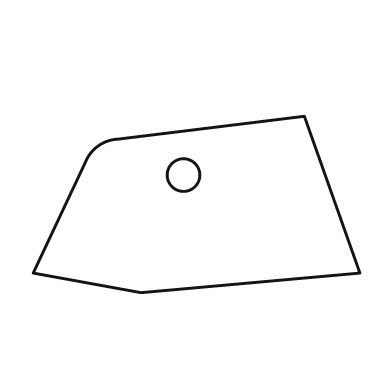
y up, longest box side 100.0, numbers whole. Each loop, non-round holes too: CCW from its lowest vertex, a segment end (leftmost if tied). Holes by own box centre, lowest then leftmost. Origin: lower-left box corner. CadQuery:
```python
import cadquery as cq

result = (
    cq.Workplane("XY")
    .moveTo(33.0, 0.0)
    .lineTo(100.0, 6.0)
    .lineTo(83.0, 54.0)
    .lineTo(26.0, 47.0)
    .threePointArc((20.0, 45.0), (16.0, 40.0))
    .lineTo(0.0, 6.0)
    .close()
    .moveTo(46.0, 36.0)
    .circle(5.0)
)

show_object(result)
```